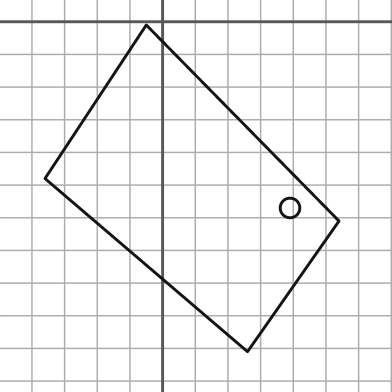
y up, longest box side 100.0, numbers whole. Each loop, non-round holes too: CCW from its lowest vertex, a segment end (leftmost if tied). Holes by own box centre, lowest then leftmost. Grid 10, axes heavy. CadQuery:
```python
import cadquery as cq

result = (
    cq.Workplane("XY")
    .moveTo(26.0, -101.0)
    .lineTo(54.0, -61.0)
    .lineTo(-5.0, -1.0)
    .lineTo(-36.0, -48.0)
    .close()
    .moveTo(39.0, -57.0)
    .circle(3.0)
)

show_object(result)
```